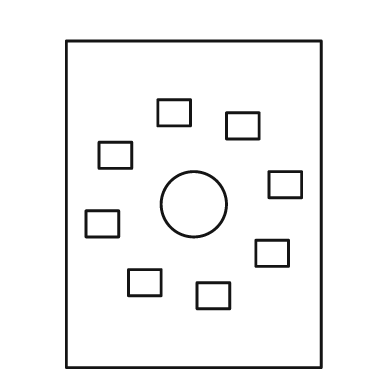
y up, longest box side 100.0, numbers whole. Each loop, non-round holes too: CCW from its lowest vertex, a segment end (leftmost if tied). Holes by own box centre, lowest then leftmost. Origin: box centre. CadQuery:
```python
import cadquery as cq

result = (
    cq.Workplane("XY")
    .moveTo(-39.0, -50.0)
    .lineTo(39.0, -50.0)
    .lineTo(39.0, 50.0)
    .lineTo(-39.0, 50.0)
    .close()
    .moveTo(1.0, -32.0)
    .lineTo(11.0, -32.0)
    .lineTo(11.0, -24.0)
    .lineTo(1.0, -24.0)
    .close()
    .moveTo(-20.0, -28.0)
    .lineTo(-10.0, -28.0)
    .lineTo(-10.0, -20.0)
    .lineTo(-20.0, -20.0)
    .close()
    .moveTo(19.0, -19.0)
    .lineTo(29.0, -19.0)
    .lineTo(29.0, -11.0)
    .lineTo(19.0, -11.0)
    .close()
    .moveTo(-33.0, -10.0)
    .lineTo(-23.0, -10.0)
    .lineTo(-23.0, -2.0)
    .lineTo(-33.0, -2.0)
    .close()
    .moveTo(0.0, 0.0)
    .circle(10.0)
    .moveTo(23.0, 2.0)
    .lineTo(33.0, 2.0)
    .lineTo(33.0, 10.0)
    .lineTo(23.0, 10.0)
    .close()
    .moveTo(-29.0, 11.0)
    .lineTo(-19.0, 11.0)
    .lineTo(-19.0, 19.0)
    .lineTo(-29.0, 19.0)
    .close()
    .moveTo(10.0, 20.0)
    .lineTo(20.0, 20.0)
    .lineTo(20.0, 28.0)
    .lineTo(10.0, 28.0)
    .close()
    .moveTo(-11.0, 24.0)
    .lineTo(-1.0, 24.0)
    .lineTo(-1.0, 32.0)
    .lineTo(-11.0, 32.0)
    .close()
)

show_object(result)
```